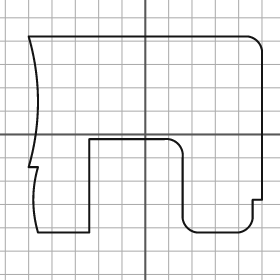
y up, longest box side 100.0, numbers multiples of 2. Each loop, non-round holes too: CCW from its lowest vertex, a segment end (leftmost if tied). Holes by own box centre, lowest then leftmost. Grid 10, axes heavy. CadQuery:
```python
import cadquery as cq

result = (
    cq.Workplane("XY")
    .moveTo(-46.0, -42.0)
    .lineTo(-24.0, -42.0)
    .lineTo(-24.0, -2.0)
    .lineTo(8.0, -2.0)
    .threePointArc((14.0, -4.0), (16.0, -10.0))
    .lineTo(16.0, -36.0)
    .threePointArc((18.0, -40.0), (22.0, -42.0))
    .lineTo(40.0, -42.0)
    .threePointArc((44.0, -40.0), (46.0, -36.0))
    .lineTo(46.0, -28.0)
    .lineTo(50.0, -28.0)
    .lineTo(50.0, 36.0)
    .threePointArc((48.0, 40.0), (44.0, 42.0))
    .lineTo(-50.0, 42.0)
    .threePointArc((-46.0, 14.0), (-50.0, -14.0))
    .lineTo(-46.0, -14.0)
    .threePointArc((-48.0, -28.0), (-46.0, -42.0))
    .close()
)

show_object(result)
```